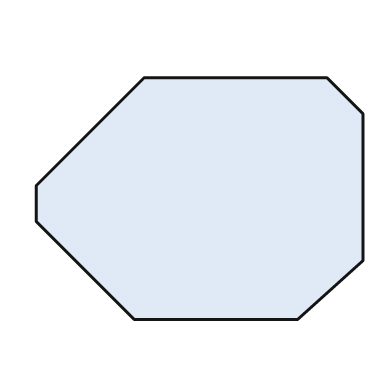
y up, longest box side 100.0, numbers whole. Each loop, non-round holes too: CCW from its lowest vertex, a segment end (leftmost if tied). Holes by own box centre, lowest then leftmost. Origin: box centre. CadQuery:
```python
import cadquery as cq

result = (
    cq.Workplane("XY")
    .moveTo(-20.0, -37.0)
    .lineTo(30.0, -37.0)
    .lineTo(50.0, -19.0)
    .lineTo(50.0, 26.0)
    .lineTo(39.0, 37.0)
    .lineTo(-17.0, 37.0)
    .lineTo(-50.0, 4.0)
    .lineTo(-50.0, -7.0)
    .close()
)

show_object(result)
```